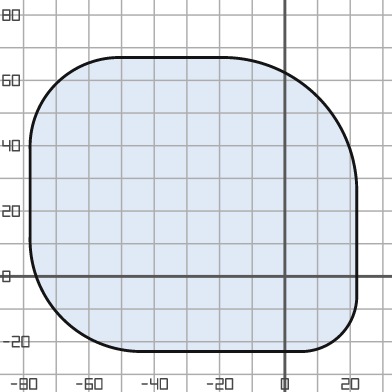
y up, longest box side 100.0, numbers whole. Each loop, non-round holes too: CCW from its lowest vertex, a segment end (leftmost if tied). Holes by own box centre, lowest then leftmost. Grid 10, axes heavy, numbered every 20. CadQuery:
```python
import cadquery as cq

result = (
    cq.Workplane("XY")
    .moveTo(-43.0, -23.0)
    .lineTo(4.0, -23.0)
    .threePointArc((17.0, -18.0), (22.0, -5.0))
    .lineTo(22.0, 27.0)
    .threePointArc((10.0, 55.0), (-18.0, 67.0))
    .lineTo(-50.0, 67.0)
    .threePointArc((-70.0, 59.0), (-78.0, 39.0))
    .lineTo(-78.0, 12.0)
    .threePointArc((-68.0, -13.0), (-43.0, -23.0))
    .close()
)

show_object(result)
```